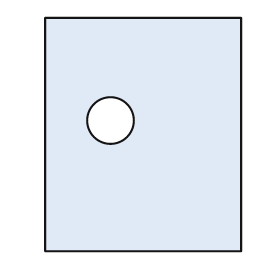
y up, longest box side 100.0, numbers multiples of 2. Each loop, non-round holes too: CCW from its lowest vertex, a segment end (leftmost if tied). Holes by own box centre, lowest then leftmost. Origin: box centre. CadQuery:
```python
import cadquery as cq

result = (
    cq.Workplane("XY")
    .moveTo(-42.0, -50.0)
    .lineTo(42.0, -50.0)
    .lineTo(42.0, 50.0)
    .lineTo(-42.0, 50.0)
    .close()
    .moveTo(-14.0, 6.0)
    .circle(10.0)
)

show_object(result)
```